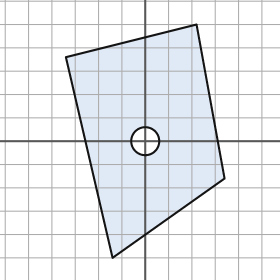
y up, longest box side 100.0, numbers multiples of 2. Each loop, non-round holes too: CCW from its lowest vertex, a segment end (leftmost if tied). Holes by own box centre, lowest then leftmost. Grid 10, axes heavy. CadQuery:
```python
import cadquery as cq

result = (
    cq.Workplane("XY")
    .moveTo(-14.0, -50.0)
    .lineTo(34.0, -16.0)
    .lineTo(22.0, 50.0)
    .lineTo(-34.0, 36.0)
    .close()
    .moveTo(0.0, 0.0)
    .circle(6.0)
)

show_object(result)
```